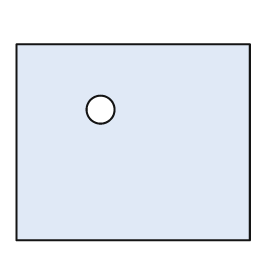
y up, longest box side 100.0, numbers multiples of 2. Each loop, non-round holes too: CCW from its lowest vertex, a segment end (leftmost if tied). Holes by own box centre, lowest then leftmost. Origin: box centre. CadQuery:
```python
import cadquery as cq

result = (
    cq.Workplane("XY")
    .moveTo(-50.0, -42.0)
    .lineTo(50.0, -42.0)
    .lineTo(50.0, 42.0)
    .lineTo(-50.0, 42.0)
    .close()
    .moveTo(-14.0, 14.0)
    .circle(6.0)
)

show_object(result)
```